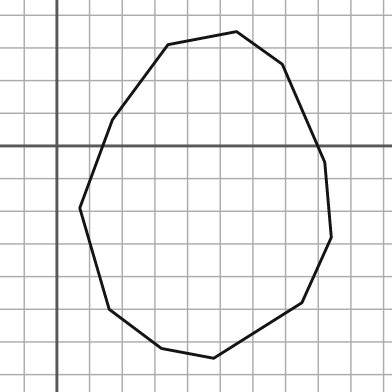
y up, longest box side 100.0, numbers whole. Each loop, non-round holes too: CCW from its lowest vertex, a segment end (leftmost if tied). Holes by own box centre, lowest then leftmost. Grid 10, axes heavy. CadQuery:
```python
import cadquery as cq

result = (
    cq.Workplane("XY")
    .moveTo(48.0, -65.0)
    .lineTo(75.0, -48.0)
    .lineTo(84.0, -28.0)
    .lineTo(82.0, -5.0)
    .lineTo(69.0, 25.0)
    .lineTo(55.0, 35.0)
    .lineTo(34.0, 31.0)
    .lineTo(17.0, 8.0)
    .lineTo(7.0, -19.0)
    .lineTo(16.0, -50.0)
    .lineTo(32.0, -62.0)
    .close()
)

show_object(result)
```